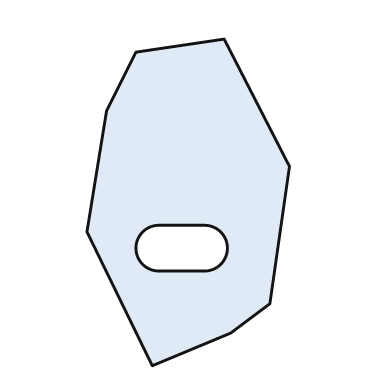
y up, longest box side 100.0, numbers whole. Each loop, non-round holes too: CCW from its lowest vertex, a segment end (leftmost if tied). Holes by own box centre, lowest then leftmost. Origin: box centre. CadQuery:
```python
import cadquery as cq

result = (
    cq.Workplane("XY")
    .moveTo(-11.0, -50.0)
    .lineTo(13.0, -40.0)
    .lineTo(25.0, -31.0)
    .lineTo(31.0, 11.0)
    .lineTo(11.0, 50.0)
    .lineTo(-16.0, 46.0)
    .lineTo(-25.0, 28.0)
    .lineTo(-31.0, -9.0)
    .close()
    .moveTo(-9.0, -21.0)
    .lineTo(5.0, -21.0)
    .threePointArc((12.0, -14.0), (5.0, -7.0))
    .lineTo(-9.0, -7.0)
    .threePointArc((-16.0, -14.0), (-9.0, -21.0))
    .close()
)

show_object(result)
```